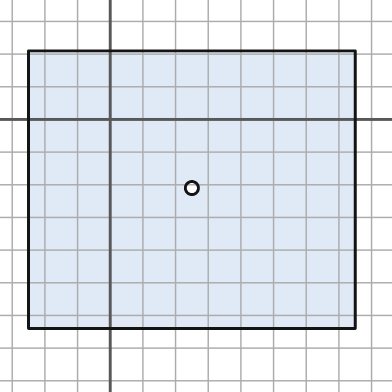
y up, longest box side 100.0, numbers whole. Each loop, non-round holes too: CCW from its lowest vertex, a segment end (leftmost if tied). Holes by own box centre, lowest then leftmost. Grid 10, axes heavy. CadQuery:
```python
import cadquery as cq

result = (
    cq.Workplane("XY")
    .moveTo(-25.0, -64.0)
    .lineTo(75.0, -64.0)
    .lineTo(75.0, 21.0)
    .lineTo(-25.0, 21.0)
    .close()
    .moveTo(25.0, -21.0)
    .circle(2.0)
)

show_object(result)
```